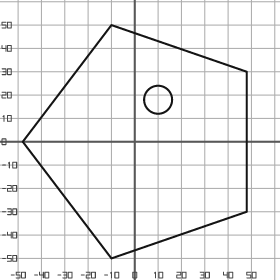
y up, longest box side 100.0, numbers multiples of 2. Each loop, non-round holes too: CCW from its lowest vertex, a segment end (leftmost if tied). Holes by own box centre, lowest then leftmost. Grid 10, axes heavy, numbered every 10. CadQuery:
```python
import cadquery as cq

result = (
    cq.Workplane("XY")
    .moveTo(-10.0, -50.0)
    .lineTo(48.0, -30.0)
    .lineTo(48.0, 30.0)
    .lineTo(-10.0, 50.0)
    .lineTo(-48.0, 0.0)
    .close()
    .moveTo(10.0, 18.0)
    .circle(6.0)
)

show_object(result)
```